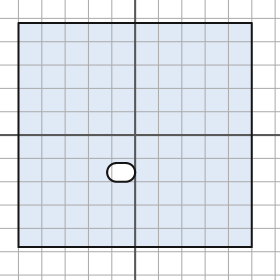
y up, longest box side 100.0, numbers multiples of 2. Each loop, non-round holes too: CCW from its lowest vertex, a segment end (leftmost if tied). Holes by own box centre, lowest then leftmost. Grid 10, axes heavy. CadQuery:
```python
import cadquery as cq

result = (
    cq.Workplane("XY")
    .moveTo(-50.0, -48.0)
    .lineTo(50.0, -48.0)
    .lineTo(50.0, 48.0)
    .lineTo(-50.0, 48.0)
    .close()
    .moveTo(-8.0, -20.0)
    .lineTo(-4.0, -20.0)
    .threePointArc((0.0, -16.0), (-4.0, -12.0))
    .lineTo(-8.0, -12.0)
    .threePointArc((-12.0, -16.0), (-8.0, -20.0))
    .close()
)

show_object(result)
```